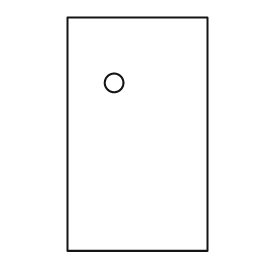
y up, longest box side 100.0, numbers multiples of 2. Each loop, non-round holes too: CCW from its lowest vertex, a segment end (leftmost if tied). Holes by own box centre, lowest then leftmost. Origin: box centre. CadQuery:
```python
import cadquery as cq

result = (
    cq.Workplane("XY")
    .moveTo(-30.0, -50.0)
    .lineTo(30.0, -50.0)
    .lineTo(30.0, 50.0)
    .lineTo(-30.0, 50.0)
    .close()
    .moveTo(-10.0, 22.0)
    .circle(4.0)
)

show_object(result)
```